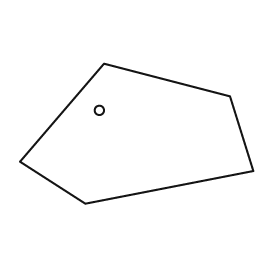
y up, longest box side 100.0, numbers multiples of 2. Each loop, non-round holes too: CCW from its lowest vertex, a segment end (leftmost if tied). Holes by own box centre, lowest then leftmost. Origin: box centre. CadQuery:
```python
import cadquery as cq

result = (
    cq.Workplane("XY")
    .moveTo(-22.0, -30.0)
    .lineTo(50.0, -16.0)
    .lineTo(40.0, 16.0)
    .lineTo(-14.0, 30.0)
    .lineTo(-50.0, -12.0)
    .close()
    .moveTo(-16.0, 10.0)
    .circle(2.0)
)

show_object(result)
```